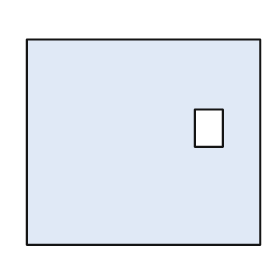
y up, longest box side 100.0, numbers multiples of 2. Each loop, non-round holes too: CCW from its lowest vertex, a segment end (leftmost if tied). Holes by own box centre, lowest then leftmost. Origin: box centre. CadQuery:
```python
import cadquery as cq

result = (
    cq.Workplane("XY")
    .moveTo(-50.0, -44.0)
    .lineTo(50.0, -44.0)
    .lineTo(50.0, 44.0)
    .lineTo(-50.0, 44.0)
    .close()
    .moveTo(22.0, -2.0)
    .lineTo(34.0, -2.0)
    .lineTo(34.0, 14.0)
    .lineTo(22.0, 14.0)
    .close()
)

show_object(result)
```